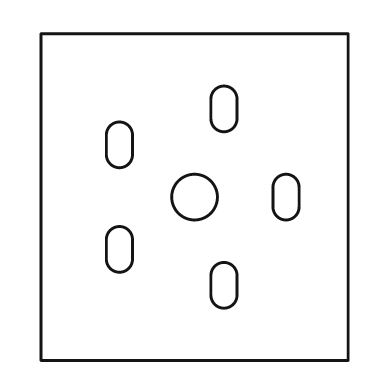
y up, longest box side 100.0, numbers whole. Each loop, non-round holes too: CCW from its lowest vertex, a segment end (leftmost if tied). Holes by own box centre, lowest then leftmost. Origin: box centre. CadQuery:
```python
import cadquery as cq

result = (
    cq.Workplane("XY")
    .moveTo(-47.0, -50.0)
    .lineTo(47.0, -50.0)
    .lineTo(47.0, 50.0)
    .lineTo(-47.0, 50.0)
    .close()
    .moveTo(5.0, -30.0)
    .threePointArc((9.0, -34.0), (13.0, -30.0))
    .lineTo(13.0, -24.0)
    .threePointArc((9.0, -20.0), (5.0, -24.0))
    .close()
    .moveTo(-27.0, -19.0)
    .threePointArc((-23.0, -23.0), (-19.0, -19.0))
    .lineTo(-19.0, -13.0)
    .threePointArc((-23.0, -9.0), (-27.0, -13.0))
    .close()
    .moveTo(0.0, 0.0)
    .circle(7.0)
    .moveTo(24.0, -3.0)
    .threePointArc((28.0, -7.0), (32.0, -3.0))
    .lineTo(32.0, 3.0)
    .threePointArc((28.0, 7.0), (24.0, 3.0))
    .close()
    .moveTo(-27.0, 13.0)
    .threePointArc((-23.0, 9.0), (-19.0, 13.0))
    .lineTo(-19.0, 19.0)
    .threePointArc((-23.0, 23.0), (-27.0, 19.0))
    .close()
    .moveTo(5.0, 24.0)
    .threePointArc((9.0, 20.0), (13.0, 24.0))
    .lineTo(13.0, 30.0)
    .threePointArc((9.0, 34.0), (5.0, 30.0))
    .close()
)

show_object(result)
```